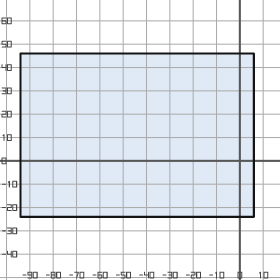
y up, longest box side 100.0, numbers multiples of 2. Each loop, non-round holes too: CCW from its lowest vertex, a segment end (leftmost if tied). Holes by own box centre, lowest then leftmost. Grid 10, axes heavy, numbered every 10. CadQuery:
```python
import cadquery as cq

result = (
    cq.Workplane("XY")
    .moveTo(-94.0, -24.0)
    .lineTo(6.0, -24.0)
    .lineTo(6.0, 46.0)
    .lineTo(-94.0, 46.0)
    .close()
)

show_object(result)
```